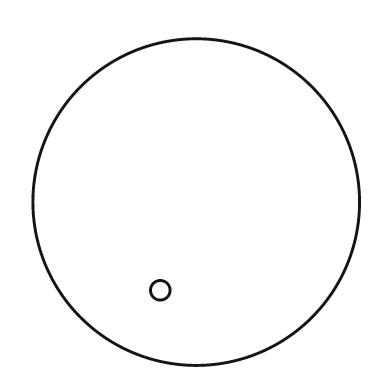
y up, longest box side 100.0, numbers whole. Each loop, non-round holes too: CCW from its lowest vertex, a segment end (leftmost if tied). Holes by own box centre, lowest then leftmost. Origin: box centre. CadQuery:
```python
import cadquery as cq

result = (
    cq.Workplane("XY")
    .moveTo(0.0, 0.0)
    .circle(50.0)
    .moveTo(-11.0, -27.0)
    .circle(3.0)
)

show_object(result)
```